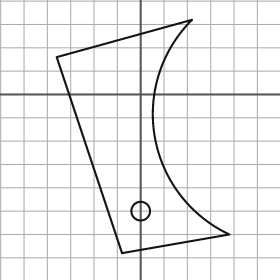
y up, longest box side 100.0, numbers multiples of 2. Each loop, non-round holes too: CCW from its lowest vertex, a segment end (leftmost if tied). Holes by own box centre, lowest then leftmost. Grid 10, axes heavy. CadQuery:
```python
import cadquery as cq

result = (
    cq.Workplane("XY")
    .moveTo(-8.0, -68.0)
    .lineTo(38.0, -60.0)
    .threePointArc((6.0, -18.0), (22.0, 32.0))
    .lineTo(-36.0, 16.0)
    .close()
    .moveTo(0.0, -50.0)
    .circle(4.0)
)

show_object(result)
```